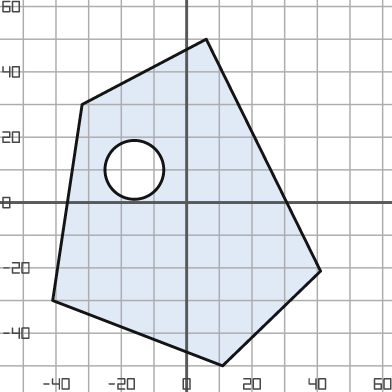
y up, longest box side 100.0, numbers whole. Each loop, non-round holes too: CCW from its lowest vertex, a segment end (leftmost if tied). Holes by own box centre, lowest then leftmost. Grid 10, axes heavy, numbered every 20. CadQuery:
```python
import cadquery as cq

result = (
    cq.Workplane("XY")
    .moveTo(11.0, -50.0)
    .lineTo(41.0, -21.0)
    .lineTo(6.0, 50.0)
    .lineTo(-32.0, 30.0)
    .lineTo(-41.0, -30.0)
    .close()
    .moveTo(-16.0, 10.0)
    .circle(9.0)
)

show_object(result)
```